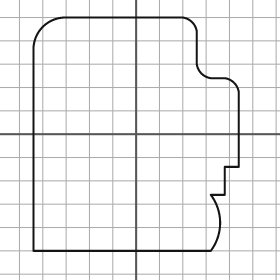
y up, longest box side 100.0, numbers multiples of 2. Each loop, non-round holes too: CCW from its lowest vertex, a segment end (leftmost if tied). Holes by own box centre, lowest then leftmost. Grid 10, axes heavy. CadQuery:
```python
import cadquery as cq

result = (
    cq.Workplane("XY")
    .moveTo(-44.0, -50.0)
    .lineTo(32.0, -50.0)
    .threePointArc((36.0, -38.0), (32.0, -26.0))
    .lineTo(38.0, -26.0)
    .lineTo(38.0, -14.0)
    .lineTo(44.0, -14.0)
    .lineTo(44.0, 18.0)
    .threePointArc((42.0, 22.0), (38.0, 24.0))
    .lineTo(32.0, 24.0)
    .threePointArc((28.0, 26.0), (26.0, 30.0))
    .lineTo(26.0, 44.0)
    .threePointArc((24.0, 48.0), (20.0, 50.0))
    .lineTo(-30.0, 50.0)
    .threePointArc((-40.0, 46.0), (-44.0, 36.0))
    .close()
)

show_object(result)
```